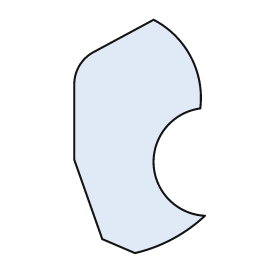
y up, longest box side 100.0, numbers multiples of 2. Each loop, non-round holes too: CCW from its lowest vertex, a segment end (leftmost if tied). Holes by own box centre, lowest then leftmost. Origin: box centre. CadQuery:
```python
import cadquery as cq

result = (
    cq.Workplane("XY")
    .moveTo(-2.0, -50.0)
    .threePointArc((14.0, -44.0), (28.0, -34.0))
    .threePointArc((6.0, -12.0), (26.0, 12.0))
    .threePointArc((22.0, 34.0), (6.0, 50.0))
    .lineTo(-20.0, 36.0)
    .threePointArc((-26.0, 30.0), (-28.0, 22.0))
    .lineTo(-28.0, -10.0)
    .lineTo(-16.0, -44.0)
    .close()
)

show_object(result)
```